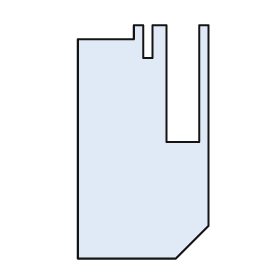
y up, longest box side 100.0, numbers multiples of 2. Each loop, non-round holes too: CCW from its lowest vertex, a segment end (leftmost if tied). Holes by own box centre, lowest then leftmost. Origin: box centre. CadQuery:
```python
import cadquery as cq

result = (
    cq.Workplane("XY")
    .moveTo(-28.0, -50.0)
    .lineTo(14.0, -50.0)
    .lineTo(28.0, -36.0)
    .lineTo(28.0, 50.0)
    .lineTo(24.0, 50.0)
    .lineTo(24.0, 0.0)
    .lineTo(10.0, 0.0)
    .lineTo(10.0, 50.0)
    .lineTo(4.0, 50.0)
    .lineTo(4.0, 36.0)
    .lineTo(0.0, 36.0)
    .lineTo(0.0, 50.0)
    .lineTo(-4.0, 50.0)
    .lineTo(-4.0, 44.0)
    .lineTo(-28.0, 44.0)
    .close()
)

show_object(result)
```